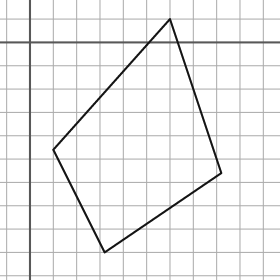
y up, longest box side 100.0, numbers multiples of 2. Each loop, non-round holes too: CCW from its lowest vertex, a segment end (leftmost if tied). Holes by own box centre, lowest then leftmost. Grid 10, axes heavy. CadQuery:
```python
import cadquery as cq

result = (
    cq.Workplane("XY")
    .moveTo(32.0, -90.0)
    .lineTo(82.0, -56.0)
    .lineTo(60.0, 10.0)
    .lineTo(10.0, -46.0)
    .close()
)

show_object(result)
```